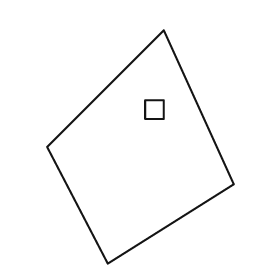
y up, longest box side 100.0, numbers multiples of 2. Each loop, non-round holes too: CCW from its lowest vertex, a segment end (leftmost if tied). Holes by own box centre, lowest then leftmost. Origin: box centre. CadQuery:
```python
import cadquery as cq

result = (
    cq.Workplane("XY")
    .moveTo(-14.0, -50.0)
    .lineTo(40.0, -16.0)
    .lineTo(10.0, 50.0)
    .lineTo(-40.0, 0.0)
    .close()
    .moveTo(2.0, 12.0)
    .lineTo(10.0, 12.0)
    .lineTo(10.0, 20.0)
    .lineTo(2.0, 20.0)
    .close()
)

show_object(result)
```